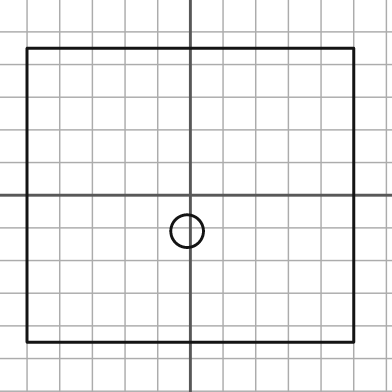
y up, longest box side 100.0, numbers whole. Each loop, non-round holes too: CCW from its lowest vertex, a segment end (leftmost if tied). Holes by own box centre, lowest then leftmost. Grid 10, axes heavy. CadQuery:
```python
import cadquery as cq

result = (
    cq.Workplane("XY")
    .moveTo(-50.0, -45.0)
    .lineTo(50.0, -45.0)
    .lineTo(50.0, 45.0)
    .lineTo(-50.0, 45.0)
    .close()
    .moveTo(-1.0, -11.0)
    .circle(5.0)
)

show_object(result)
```